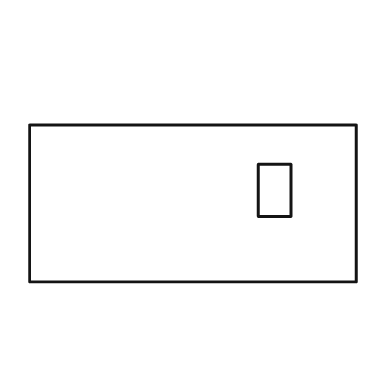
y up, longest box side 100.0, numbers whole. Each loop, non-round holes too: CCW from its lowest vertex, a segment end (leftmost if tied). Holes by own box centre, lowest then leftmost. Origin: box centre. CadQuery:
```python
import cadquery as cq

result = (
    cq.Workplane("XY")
    .moveTo(-50.0, -24.0)
    .lineTo(50.0, -24.0)
    .lineTo(50.0, 24.0)
    .lineTo(-50.0, 24.0)
    .close()
    .moveTo(20.0, -4.0)
    .lineTo(30.0, -4.0)
    .lineTo(30.0, 12.0)
    .lineTo(20.0, 12.0)
    .close()
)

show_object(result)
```